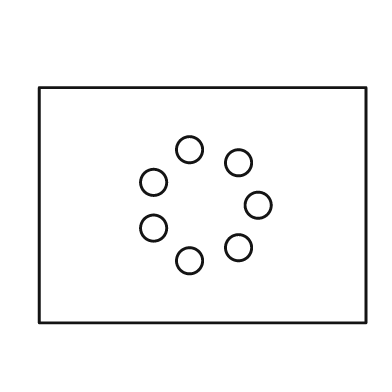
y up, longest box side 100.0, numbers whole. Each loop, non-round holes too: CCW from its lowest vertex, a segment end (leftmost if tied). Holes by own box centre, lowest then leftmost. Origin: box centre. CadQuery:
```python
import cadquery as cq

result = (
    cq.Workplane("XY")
    .moveTo(-50.0, -36.0)
    .lineTo(50.0, -36.0)
    .lineTo(50.0, 36.0)
    .lineTo(-50.0, 36.0)
    .close()
    .moveTo(-4.0, -17.0)
    .circle(4.0)
    .moveTo(11.0, -13.0)
    .circle(4.0)
    .moveTo(-15.0, -7.0)
    .circle(4.0)
    .moveTo(17.0, 0.0)
    .circle(4.0)
    .moveTo(-15.0, 7.0)
    .circle(4.0)
    .moveTo(11.0, 13.0)
    .circle(4.0)
    .moveTo(-4.0, 17.0)
    .circle(4.0)
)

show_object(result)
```